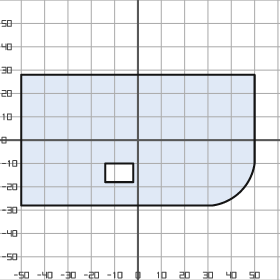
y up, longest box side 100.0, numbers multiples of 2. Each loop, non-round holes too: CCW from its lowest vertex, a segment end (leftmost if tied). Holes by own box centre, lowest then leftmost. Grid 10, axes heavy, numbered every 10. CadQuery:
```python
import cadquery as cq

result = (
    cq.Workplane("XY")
    .moveTo(-50.0, -28.0)
    .lineTo(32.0, -28.0)
    .threePointArc((44.0, -22.0), (50.0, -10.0))
    .lineTo(50.0, 28.0)
    .lineTo(-50.0, 28.0)
    .close()
    .moveTo(-14.0, -18.0)
    .lineTo(-2.0, -18.0)
    .lineTo(-2.0, -10.0)
    .lineTo(-14.0, -10.0)
    .close()
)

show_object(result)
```